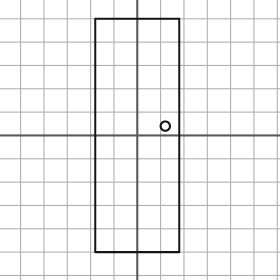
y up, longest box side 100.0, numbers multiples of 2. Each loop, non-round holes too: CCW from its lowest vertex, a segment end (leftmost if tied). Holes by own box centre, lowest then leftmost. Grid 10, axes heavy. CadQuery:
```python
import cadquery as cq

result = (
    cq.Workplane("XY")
    .moveTo(-18.0, -50.0)
    .lineTo(18.0, -50.0)
    .lineTo(18.0, 50.0)
    .lineTo(-18.0, 50.0)
    .close()
    .moveTo(12.0, 4.0)
    .circle(2.0)
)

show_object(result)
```